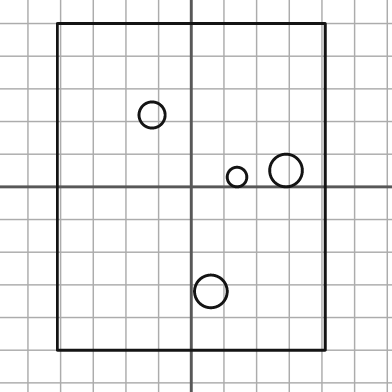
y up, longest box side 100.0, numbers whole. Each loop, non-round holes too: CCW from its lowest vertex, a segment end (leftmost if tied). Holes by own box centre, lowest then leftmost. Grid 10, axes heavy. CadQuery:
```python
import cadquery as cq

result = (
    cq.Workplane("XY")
    .moveTo(-41.0, -50.0)
    .lineTo(41.0, -50.0)
    .lineTo(41.0, 50.0)
    .lineTo(-41.0, 50.0)
    .close()
    .moveTo(6.0, -32.0)
    .circle(5.0)
    .moveTo(14.0, 3.0)
    .circle(3.0)
    .moveTo(29.0, 5.0)
    .circle(5.0)
    .moveTo(-12.0, 22.0)
    .circle(4.0)
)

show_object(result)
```